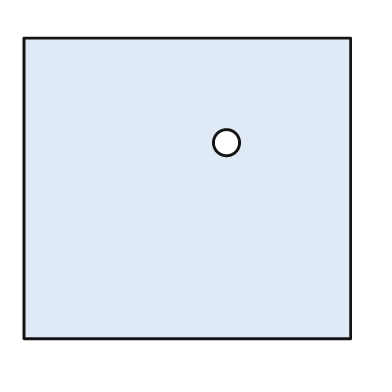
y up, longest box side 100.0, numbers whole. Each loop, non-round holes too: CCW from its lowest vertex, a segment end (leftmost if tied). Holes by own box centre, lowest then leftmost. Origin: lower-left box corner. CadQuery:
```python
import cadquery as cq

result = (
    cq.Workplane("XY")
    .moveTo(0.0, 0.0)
    .lineTo(100.0, 0.0)
    .lineTo(100.0, 92.0)
    .lineTo(0.0, 92.0)
    .close()
    .moveTo(62.0, 60.0)
    .circle(4.0)
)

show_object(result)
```